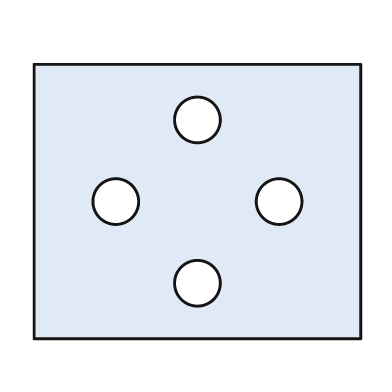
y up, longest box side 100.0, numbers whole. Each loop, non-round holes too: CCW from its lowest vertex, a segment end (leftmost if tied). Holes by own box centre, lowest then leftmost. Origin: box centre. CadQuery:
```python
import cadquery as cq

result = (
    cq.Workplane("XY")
    .moveTo(-50.0, -42.0)
    .lineTo(50.0, -42.0)
    .lineTo(50.0, 42.0)
    .lineTo(-50.0, 42.0)
    .close()
    .moveTo(0.0, -25.0)
    .circle(7.0)
    .moveTo(-25.0, 0.0)
    .circle(7.0)
    .moveTo(25.0, 0.0)
    .circle(7.0)
    .moveTo(0.0, 25.0)
    .circle(7.0)
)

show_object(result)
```